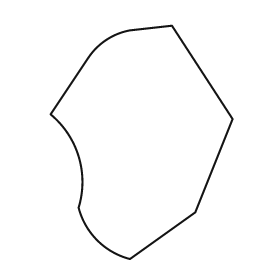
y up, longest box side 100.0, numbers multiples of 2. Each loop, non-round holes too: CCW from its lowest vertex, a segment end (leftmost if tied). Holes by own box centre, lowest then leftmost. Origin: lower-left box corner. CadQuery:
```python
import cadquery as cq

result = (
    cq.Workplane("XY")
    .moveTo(34.0, 0.0)
    .lineTo(62.0, 20.0)
    .lineTo(78.0, 60.0)
    .lineTo(52.0, 100.0)
    .lineTo(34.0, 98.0)
    .threePointArc((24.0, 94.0), (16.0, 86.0))
    .lineTo(0.0, 62.0)
    .threePointArc((12.0, 44.0), (12.0, 22.0))
    .threePointArc((20.0, 8.0), (34.0, 0.0))
    .close()
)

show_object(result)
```